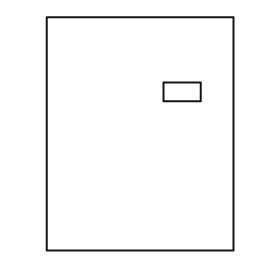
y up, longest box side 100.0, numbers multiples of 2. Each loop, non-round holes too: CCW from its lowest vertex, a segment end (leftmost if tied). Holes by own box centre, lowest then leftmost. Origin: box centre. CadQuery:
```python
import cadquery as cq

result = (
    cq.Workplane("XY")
    .moveTo(-40.0, -50.0)
    .lineTo(40.0, -50.0)
    .lineTo(40.0, 50.0)
    .lineTo(-40.0, 50.0)
    .close()
    .moveTo(10.0, 14.0)
    .lineTo(26.0, 14.0)
    .lineTo(26.0, 22.0)
    .lineTo(10.0, 22.0)
    .close()
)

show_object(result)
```